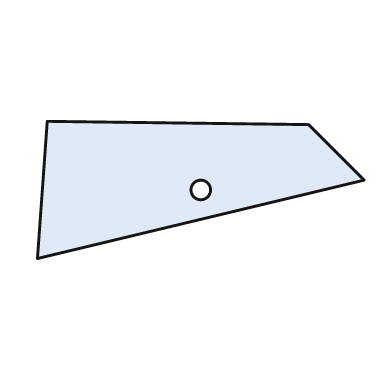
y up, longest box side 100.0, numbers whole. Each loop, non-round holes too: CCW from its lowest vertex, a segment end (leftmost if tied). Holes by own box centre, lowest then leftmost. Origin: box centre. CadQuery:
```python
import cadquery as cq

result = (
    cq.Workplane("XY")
    .moveTo(-50.0, -21.0)
    .lineTo(50.0, 3.0)
    .lineTo(33.0, 20.0)
    .lineTo(-47.0, 21.0)
    .close()
    .moveTo(0.0, 0.0)
    .circle(3.0)
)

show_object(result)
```